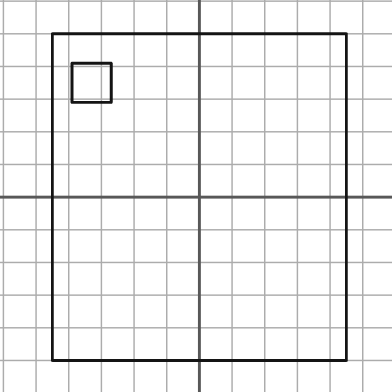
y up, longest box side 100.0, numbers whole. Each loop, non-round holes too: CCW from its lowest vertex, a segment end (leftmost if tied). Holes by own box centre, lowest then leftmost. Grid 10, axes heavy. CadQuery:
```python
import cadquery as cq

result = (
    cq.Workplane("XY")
    .moveTo(-45.0, -50.0)
    .lineTo(45.0, -50.0)
    .lineTo(45.0, 50.0)
    .lineTo(-45.0, 50.0)
    .close()
    .moveTo(-39.0, 29.0)
    .lineTo(-27.0, 29.0)
    .lineTo(-27.0, 41.0)
    .lineTo(-39.0, 41.0)
    .close()
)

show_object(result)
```